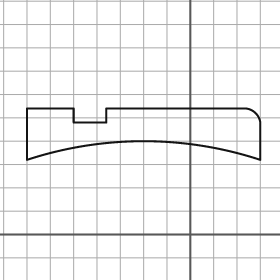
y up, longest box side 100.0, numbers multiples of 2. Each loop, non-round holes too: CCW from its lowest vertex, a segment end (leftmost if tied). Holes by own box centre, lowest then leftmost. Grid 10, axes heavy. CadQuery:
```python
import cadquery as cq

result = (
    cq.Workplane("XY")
    .moveTo(-70.0, 32.0)
    .threePointArc((-20.0, 40.0), (30.0, 32.0))
    .lineTo(30.0, 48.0)
    .threePointArc((28.0, 52.0), (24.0, 54.0))
    .lineTo(-36.0, 54.0)
    .lineTo(-36.0, 48.0)
    .lineTo(-50.0, 48.0)
    .lineTo(-50.0, 54.0)
    .lineTo(-70.0, 54.0)
    .close()
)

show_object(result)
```